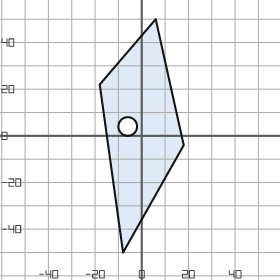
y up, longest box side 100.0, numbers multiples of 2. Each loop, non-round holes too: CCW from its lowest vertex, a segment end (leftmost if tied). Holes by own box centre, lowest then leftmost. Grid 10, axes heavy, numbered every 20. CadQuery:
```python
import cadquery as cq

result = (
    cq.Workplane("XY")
    .moveTo(-8.0, -50.0)
    .lineTo(18.0, -4.0)
    .lineTo(6.0, 50.0)
    .lineTo(-18.0, 22.0)
    .close()
    .moveTo(-6.0, 4.0)
    .circle(4.0)
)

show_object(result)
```